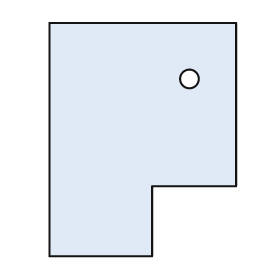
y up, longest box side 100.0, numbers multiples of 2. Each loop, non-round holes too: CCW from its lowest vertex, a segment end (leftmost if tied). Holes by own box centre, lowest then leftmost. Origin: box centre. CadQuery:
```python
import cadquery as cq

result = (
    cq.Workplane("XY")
    .moveTo(-40.0, -50.0)
    .lineTo(4.0, -50.0)
    .lineTo(4.0, -20.0)
    .lineTo(40.0, -20.0)
    .lineTo(40.0, 50.0)
    .lineTo(-40.0, 50.0)
    .close()
    .moveTo(20.0, 26.0)
    .circle(4.0)
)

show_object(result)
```